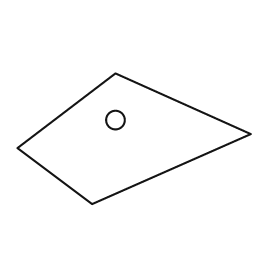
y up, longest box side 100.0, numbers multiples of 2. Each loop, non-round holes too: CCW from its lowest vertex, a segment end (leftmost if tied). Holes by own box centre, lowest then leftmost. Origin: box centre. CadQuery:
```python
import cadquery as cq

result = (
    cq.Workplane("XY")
    .moveTo(-18.0, -28.0)
    .lineTo(50.0, 2.0)
    .lineTo(-8.0, 28.0)
    .lineTo(-50.0, -4.0)
    .close()
    .moveTo(-8.0, 8.0)
    .circle(4.0)
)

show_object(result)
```